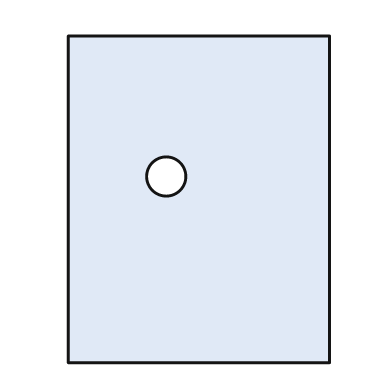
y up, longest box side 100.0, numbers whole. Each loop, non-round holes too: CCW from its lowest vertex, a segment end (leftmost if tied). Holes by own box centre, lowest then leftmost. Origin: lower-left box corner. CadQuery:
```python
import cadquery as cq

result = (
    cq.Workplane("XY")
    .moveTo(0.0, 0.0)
    .lineTo(80.0, 0.0)
    .lineTo(80.0, 100.0)
    .lineTo(0.0, 100.0)
    .close()
    .moveTo(30.0, 57.0)
    .circle(6.0)
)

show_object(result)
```